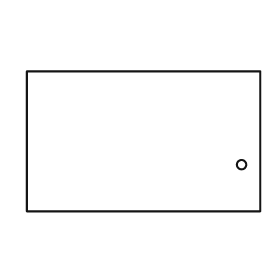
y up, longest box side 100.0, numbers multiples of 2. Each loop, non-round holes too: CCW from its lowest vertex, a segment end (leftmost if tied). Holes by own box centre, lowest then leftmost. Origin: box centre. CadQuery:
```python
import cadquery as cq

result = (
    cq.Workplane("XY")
    .moveTo(-50.0, -30.0)
    .lineTo(50.0, -30.0)
    .lineTo(50.0, 30.0)
    .lineTo(-50.0, 30.0)
    .close()
    .moveTo(42.0, -10.0)
    .circle(2.0)
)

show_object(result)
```